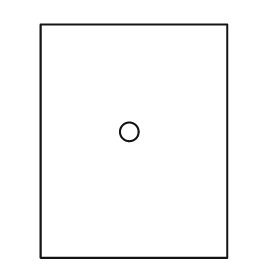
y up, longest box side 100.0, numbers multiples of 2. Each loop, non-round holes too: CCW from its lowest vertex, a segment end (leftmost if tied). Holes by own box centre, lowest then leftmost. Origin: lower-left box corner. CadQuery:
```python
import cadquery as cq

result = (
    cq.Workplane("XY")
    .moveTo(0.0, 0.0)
    .lineTo(80.0, 0.0)
    .lineTo(80.0, 100.0)
    .lineTo(0.0, 100.0)
    .close()
    .moveTo(38.0, 54.0)
    .circle(4.0)
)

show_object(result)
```